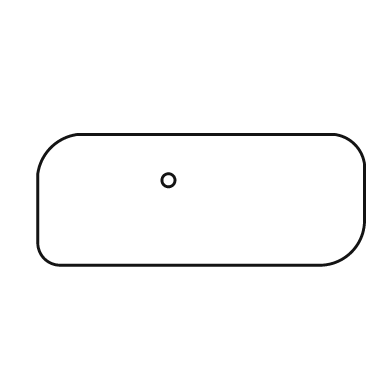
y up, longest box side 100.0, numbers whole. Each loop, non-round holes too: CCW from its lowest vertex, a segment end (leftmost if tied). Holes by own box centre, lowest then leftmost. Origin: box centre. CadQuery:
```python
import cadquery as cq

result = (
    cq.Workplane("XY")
    .moveTo(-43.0, -20.0)
    .lineTo(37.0, -20.0)
    .threePointArc((46.0, -16.0), (50.0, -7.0))
    .lineTo(50.0, 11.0)
    .threePointArc((47.0, 17.0), (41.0, 20.0))
    .lineTo(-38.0, 20.0)
    .threePointArc((-46.0, 16.0), (-50.0, 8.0))
    .lineTo(-50.0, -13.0)
    .threePointArc((-48.0, -18.0), (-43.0, -20.0))
    .close()
    .moveTo(-10.0, 6.0)
    .circle(2.0)
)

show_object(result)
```